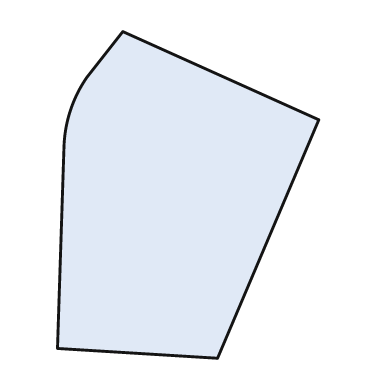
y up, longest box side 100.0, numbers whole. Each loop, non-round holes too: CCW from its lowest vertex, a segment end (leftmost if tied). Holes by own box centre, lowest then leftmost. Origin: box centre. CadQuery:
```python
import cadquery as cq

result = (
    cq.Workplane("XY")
    .moveTo(9.0, -50.0)
    .lineTo(40.0, 23.0)
    .lineTo(-20.0, 50.0)
    .lineTo(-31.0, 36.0)
    .threePointArc((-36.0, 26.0), (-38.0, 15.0))
    .lineTo(-40.0, -47.0)
    .close()
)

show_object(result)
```